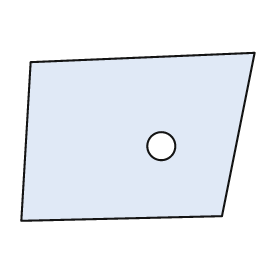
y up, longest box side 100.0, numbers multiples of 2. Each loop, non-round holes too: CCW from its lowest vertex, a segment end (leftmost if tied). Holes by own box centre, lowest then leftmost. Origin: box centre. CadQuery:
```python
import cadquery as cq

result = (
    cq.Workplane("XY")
    .moveTo(-50.0, -36.0)
    .lineTo(36.0, -34.0)
    .lineTo(50.0, 36.0)
    .lineTo(-46.0, 32.0)
    .close()
    .moveTo(10.0, -4.0)
    .circle(6.0)
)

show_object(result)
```